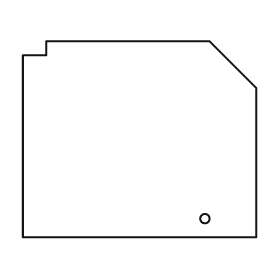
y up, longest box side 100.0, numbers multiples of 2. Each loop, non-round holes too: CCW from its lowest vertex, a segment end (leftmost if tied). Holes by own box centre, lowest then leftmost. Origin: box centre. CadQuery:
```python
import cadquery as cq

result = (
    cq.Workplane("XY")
    .moveTo(-50.0, -42.0)
    .lineTo(50.0, -42.0)
    .lineTo(50.0, 22.0)
    .lineTo(30.0, 42.0)
    .lineTo(-40.0, 42.0)
    .lineTo(-40.0, 36.0)
    .lineTo(-50.0, 36.0)
    .close()
    .moveTo(28.0, -34.0)
    .circle(2.0)
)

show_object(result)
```